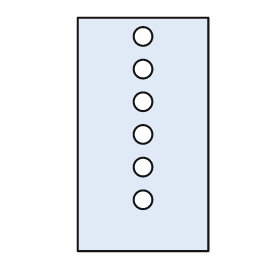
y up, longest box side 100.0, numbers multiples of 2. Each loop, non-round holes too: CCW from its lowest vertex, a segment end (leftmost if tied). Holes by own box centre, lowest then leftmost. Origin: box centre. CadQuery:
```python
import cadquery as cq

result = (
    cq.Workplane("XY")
    .moveTo(-28.0, -50.0)
    .lineTo(28.0, -50.0)
    .lineTo(28.0, 50.0)
    .lineTo(-28.0, 50.0)
    .close()
    .moveTo(0.0, -28.0)
    .circle(4.0)
    .moveTo(0.0, -14.0)
    .circle(4.0)
    .moveTo(0.0, 0.0)
    .circle(4.0)
    .moveTo(0.0, 14.0)
    .circle(4.0)
    .moveTo(0.0, 28.0)
    .circle(4.0)
    .moveTo(0.0, 42.0)
    .circle(4.0)
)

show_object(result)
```